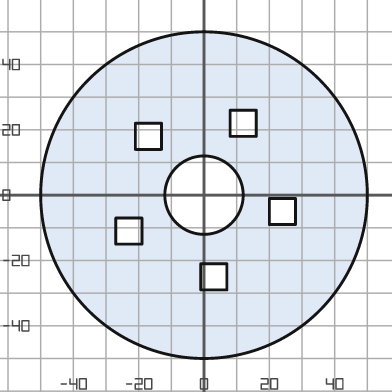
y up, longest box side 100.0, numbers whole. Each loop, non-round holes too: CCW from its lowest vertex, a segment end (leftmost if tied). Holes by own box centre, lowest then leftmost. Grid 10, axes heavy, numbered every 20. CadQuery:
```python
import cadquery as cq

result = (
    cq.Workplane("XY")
    .moveTo(0.0, 0.0)
    .circle(50.0)
    .moveTo(-1.0, -29.0)
    .lineTo(7.0, -29.0)
    .lineTo(7.0, -21.0)
    .lineTo(-1.0, -21.0)
    .close()
    .moveTo(-27.0, -15.0)
    .lineTo(-19.0, -15.0)
    .lineTo(-19.0, -7.0)
    .lineTo(-27.0, -7.0)
    .close()
    .moveTo(20.0, -9.0)
    .lineTo(28.0, -9.0)
    .lineTo(28.0, -1.0)
    .lineTo(20.0, -1.0)
    .close()
    .moveTo(0.0, 0.0)
    .circle(12.0)
    .moveTo(-21.0, 14.0)
    .lineTo(-13.0, 14.0)
    .lineTo(-13.0, 22.0)
    .lineTo(-21.0, 22.0)
    .close()
    .moveTo(8.0, 18.0)
    .lineTo(16.0, 18.0)
    .lineTo(16.0, 26.0)
    .lineTo(8.0, 26.0)
    .close()
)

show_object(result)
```